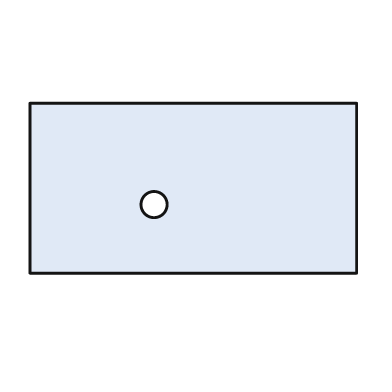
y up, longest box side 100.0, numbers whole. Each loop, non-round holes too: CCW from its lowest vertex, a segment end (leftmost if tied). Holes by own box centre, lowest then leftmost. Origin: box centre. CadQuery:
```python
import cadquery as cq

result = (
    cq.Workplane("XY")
    .moveTo(-50.0, -26.0)
    .lineTo(50.0, -26.0)
    .lineTo(50.0, 26.0)
    .lineTo(-50.0, 26.0)
    .close()
    .moveTo(-12.0, -5.0)
    .circle(4.0)
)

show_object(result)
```